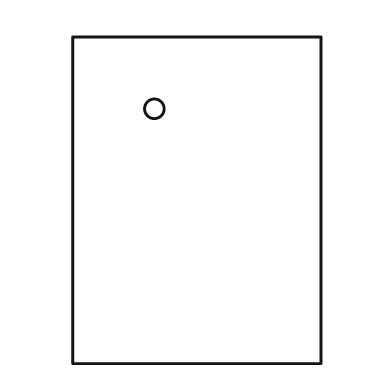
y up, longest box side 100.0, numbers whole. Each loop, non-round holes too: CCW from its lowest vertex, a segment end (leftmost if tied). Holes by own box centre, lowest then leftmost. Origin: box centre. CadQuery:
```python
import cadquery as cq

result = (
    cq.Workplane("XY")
    .moveTo(-38.0, -50.0)
    .lineTo(38.0, -50.0)
    .lineTo(38.0, 50.0)
    .lineTo(-38.0, 50.0)
    .close()
    .moveTo(-13.0, 28.0)
    .circle(3.0)
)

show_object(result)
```